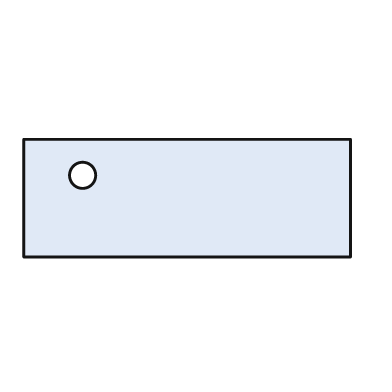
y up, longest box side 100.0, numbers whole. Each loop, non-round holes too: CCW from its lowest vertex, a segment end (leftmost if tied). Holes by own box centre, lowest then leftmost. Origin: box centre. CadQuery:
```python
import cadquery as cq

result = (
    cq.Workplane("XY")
    .moveTo(-50.0, -18.0)
    .lineTo(50.0, -18.0)
    .lineTo(50.0, 18.0)
    .lineTo(-50.0, 18.0)
    .close()
    .moveTo(-32.0, 7.0)
    .circle(4.0)
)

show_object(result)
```